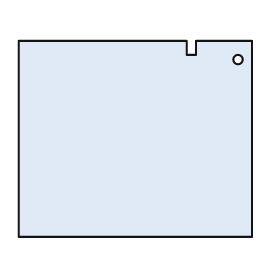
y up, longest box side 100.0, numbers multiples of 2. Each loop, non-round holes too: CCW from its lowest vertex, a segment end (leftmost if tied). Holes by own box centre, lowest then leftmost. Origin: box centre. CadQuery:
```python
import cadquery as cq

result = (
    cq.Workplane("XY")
    .moveTo(-50.0, -42.0)
    .lineTo(50.0, -42.0)
    .lineTo(50.0, 42.0)
    .lineTo(26.0, 42.0)
    .lineTo(26.0, 36.0)
    .lineTo(22.0, 36.0)
    .lineTo(22.0, 42.0)
    .lineTo(-50.0, 42.0)
    .close()
    .moveTo(44.0, 34.0)
    .circle(2.0)
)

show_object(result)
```